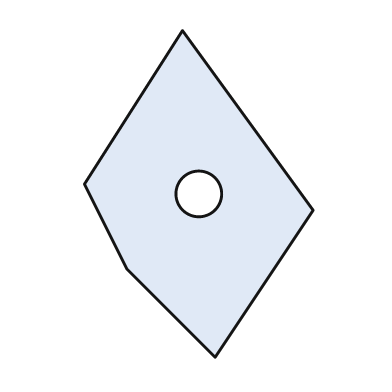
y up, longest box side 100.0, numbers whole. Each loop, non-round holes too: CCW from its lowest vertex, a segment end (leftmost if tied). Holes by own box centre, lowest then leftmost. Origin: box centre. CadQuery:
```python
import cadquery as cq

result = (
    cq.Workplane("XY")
    .moveTo(5.0, -50.0)
    .lineTo(35.0, -5.0)
    .lineTo(-5.0, 50.0)
    .lineTo(-35.0, 3.0)
    .lineTo(-22.0, -23.0)
    .close()
    .moveTo(0.0, 0.0)
    .circle(7.0)
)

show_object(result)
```